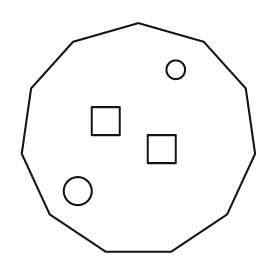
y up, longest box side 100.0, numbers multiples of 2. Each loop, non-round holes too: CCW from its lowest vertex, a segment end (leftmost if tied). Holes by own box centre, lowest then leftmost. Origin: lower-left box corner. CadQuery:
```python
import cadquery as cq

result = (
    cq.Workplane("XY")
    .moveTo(36.0, 0.0)
    .lineTo(64.0, 0.0)
    .lineTo(88.0, 16.0)
    .lineTo(100.0, 42.0)
    .lineTo(96.0, 70.0)
    .lineTo(78.0, 90.0)
    .lineTo(50.0, 98.0)
    .lineTo(22.0, 90.0)
    .lineTo(4.0, 70.0)
    .lineTo(0.0, 42.0)
    .lineTo(12.0, 16.0)
    .close()
    .moveTo(24.0, 26.0)
    .circle(6.0)
    .moveTo(54.0, 38.0)
    .lineTo(66.0, 38.0)
    .lineTo(66.0, 50.0)
    .lineTo(54.0, 50.0)
    .close()
    .moveTo(30.0, 50.0)
    .lineTo(42.0, 50.0)
    .lineTo(42.0, 62.0)
    .lineTo(30.0, 62.0)
    .close()
    .moveTo(66.0, 78.0)
    .circle(4.0)
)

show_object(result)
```